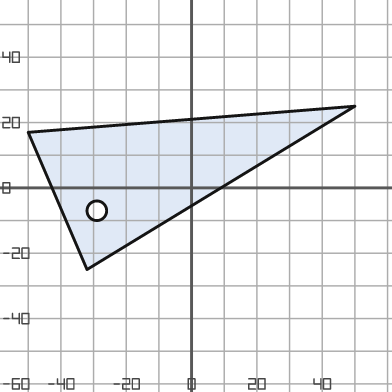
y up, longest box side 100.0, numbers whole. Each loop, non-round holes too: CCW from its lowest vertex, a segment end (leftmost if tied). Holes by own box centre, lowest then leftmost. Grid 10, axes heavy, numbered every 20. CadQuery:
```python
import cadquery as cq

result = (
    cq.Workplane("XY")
    .moveTo(-32.0, -25.0)
    .lineTo(50.0, 25.0)
    .lineTo(-50.0, 17.0)
    .close()
    .moveTo(-29.0, -7.0)
    .circle(3.0)
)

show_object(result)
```